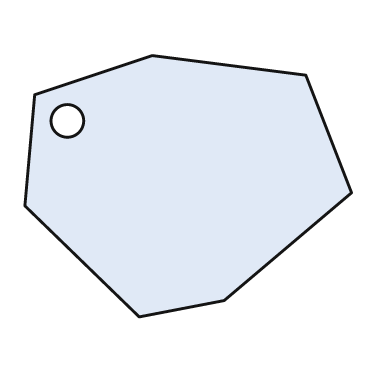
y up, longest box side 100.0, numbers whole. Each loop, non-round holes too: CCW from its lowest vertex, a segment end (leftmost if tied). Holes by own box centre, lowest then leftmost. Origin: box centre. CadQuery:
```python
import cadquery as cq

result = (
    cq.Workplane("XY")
    .moveTo(-15.0, -40.0)
    .lineTo(11.0, -35.0)
    .lineTo(50.0, -2.0)
    .lineTo(36.0, 34.0)
    .lineTo(-11.0, 40.0)
    .lineTo(-47.0, 28.0)
    .lineTo(-50.0, -6.0)
    .close()
    .moveTo(-37.0, 20.0)
    .circle(5.0)
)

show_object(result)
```